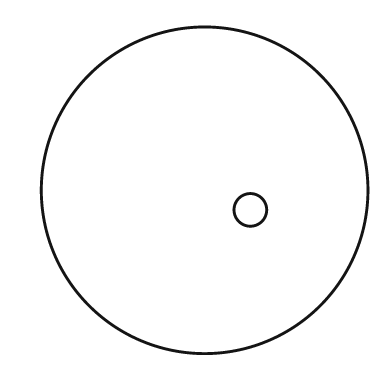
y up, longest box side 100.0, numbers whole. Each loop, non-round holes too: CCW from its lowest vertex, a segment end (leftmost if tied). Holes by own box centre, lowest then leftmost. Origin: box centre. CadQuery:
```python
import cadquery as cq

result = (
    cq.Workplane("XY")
    .moveTo(0.0, 0.0)
    .circle(50.0)
    .moveTo(14.0, -6.0)
    .circle(5.0)
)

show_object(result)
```